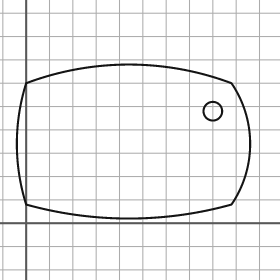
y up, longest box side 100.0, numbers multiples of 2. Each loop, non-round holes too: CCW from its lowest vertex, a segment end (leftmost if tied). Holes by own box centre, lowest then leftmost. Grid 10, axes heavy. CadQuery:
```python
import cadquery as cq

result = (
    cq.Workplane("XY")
    .moveTo(0.0, 8.0)
    .threePointArc((44.0, 2.0), (88.0, 8.0))
    .threePointArc((96.0, 34.0), (88.0, 60.0))
    .threePointArc((44.0, 68.0), (0.0, 60.0))
    .threePointArc((-4.0, 34.0), (0.0, 8.0))
    .close()
    .moveTo(80.0, 48.0)
    .circle(4.0)
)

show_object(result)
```